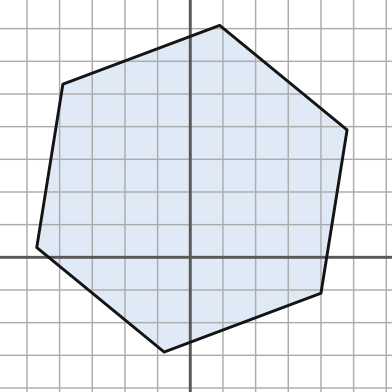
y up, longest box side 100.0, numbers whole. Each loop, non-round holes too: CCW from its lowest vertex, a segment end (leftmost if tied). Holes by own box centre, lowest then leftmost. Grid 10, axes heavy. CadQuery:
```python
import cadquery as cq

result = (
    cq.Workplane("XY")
    .moveTo(-8.0, -29.0)
    .lineTo(40.0, -11.0)
    .lineTo(48.0, 39.0)
    .lineTo(9.0, 71.0)
    .lineTo(-39.0, 53.0)
    .lineTo(-47.0, 3.0)
    .close()
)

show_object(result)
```